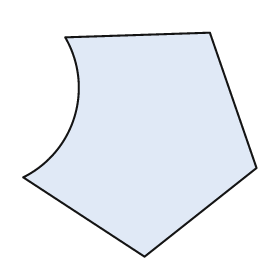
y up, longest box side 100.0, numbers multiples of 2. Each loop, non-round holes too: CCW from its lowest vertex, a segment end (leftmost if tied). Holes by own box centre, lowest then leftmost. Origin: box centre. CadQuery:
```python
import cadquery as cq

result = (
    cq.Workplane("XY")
    .moveTo(2.0, -48.0)
    .lineTo(50.0, -10.0)
    .lineTo(30.0, 48.0)
    .lineTo(-32.0, 46.0)
    .threePointArc((-28.0, 12.0), (-50.0, -14.0))
    .close()
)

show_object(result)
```